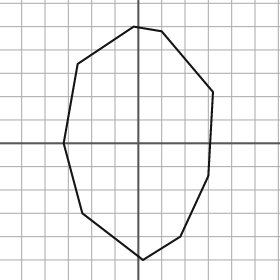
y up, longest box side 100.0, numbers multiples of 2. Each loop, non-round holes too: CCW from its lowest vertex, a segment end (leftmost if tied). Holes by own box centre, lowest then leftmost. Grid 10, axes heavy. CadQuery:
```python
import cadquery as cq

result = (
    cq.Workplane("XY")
    .moveTo(2.0, -50.0)
    .lineTo(18.0, -40.0)
    .lineTo(30.0, -14.0)
    .lineTo(32.0, 22.0)
    .lineTo(10.0, 48.0)
    .lineTo(-2.0, 50.0)
    .lineTo(-26.0, 34.0)
    .lineTo(-32.0, 0.0)
    .lineTo(-24.0, -30.0)
    .close()
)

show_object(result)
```